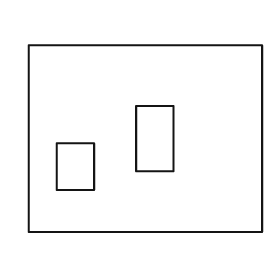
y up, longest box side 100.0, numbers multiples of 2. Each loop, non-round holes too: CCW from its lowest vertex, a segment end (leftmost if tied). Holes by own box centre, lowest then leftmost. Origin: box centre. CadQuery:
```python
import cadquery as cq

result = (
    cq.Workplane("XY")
    .moveTo(-50.0, -40.0)
    .lineTo(50.0, -40.0)
    .lineTo(50.0, 40.0)
    .lineTo(-50.0, 40.0)
    .close()
    .moveTo(-38.0, -22.0)
    .lineTo(-22.0, -22.0)
    .lineTo(-22.0, -2.0)
    .lineTo(-38.0, -2.0)
    .close()
    .moveTo(-4.0, -14.0)
    .lineTo(12.0, -14.0)
    .lineTo(12.0, 14.0)
    .lineTo(-4.0, 14.0)
    .close()
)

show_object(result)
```